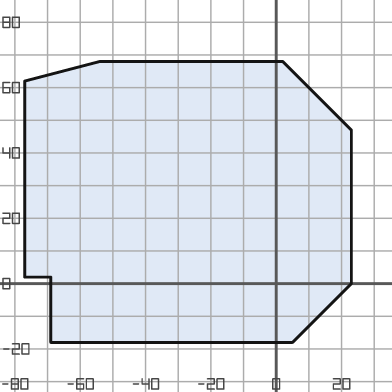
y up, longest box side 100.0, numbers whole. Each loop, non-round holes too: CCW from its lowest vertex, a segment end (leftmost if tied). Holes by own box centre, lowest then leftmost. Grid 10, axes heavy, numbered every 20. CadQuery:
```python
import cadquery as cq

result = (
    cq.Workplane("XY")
    .moveTo(-69.0, -18.0)
    .lineTo(5.0, -18.0)
    .lineTo(23.0, 0.0)
    .lineTo(23.0, 47.0)
    .lineTo(2.0, 68.0)
    .lineTo(-54.0, 68.0)
    .lineTo(-77.0, 62.0)
    .lineTo(-77.0, 2.0)
    .lineTo(-69.0, 2.0)
    .close()
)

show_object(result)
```